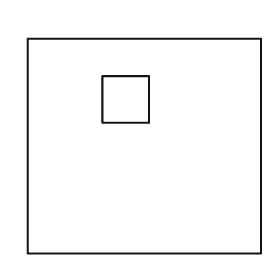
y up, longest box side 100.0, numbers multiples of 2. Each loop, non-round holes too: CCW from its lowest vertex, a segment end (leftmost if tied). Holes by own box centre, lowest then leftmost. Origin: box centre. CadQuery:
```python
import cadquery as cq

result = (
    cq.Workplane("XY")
    .moveTo(-50.0, -46.0)
    .lineTo(50.0, -46.0)
    .lineTo(50.0, 46.0)
    .lineTo(-50.0, 46.0)
    .close()
    .moveTo(-18.0, 10.0)
    .lineTo(2.0, 10.0)
    .lineTo(2.0, 30.0)
    .lineTo(-18.0, 30.0)
    .close()
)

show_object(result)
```